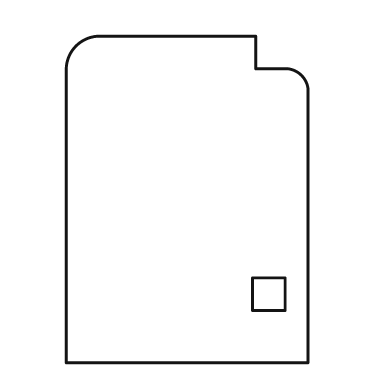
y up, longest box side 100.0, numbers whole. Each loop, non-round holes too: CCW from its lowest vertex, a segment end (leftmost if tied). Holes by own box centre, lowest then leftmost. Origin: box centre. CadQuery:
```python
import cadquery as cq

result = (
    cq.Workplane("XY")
    .moveTo(-37.0, -50.0)
    .lineTo(37.0, -50.0)
    .lineTo(37.0, 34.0)
    .threePointArc((35.0, 38.0), (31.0, 40.0))
    .lineTo(21.0, 40.0)
    .lineTo(21.0, 50.0)
    .lineTo(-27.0, 50.0)
    .threePointArc((-34.0, 47.0), (-37.0, 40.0))
    .close()
    .moveTo(20.0, -34.0)
    .lineTo(30.0, -34.0)
    .lineTo(30.0, -24.0)
    .lineTo(20.0, -24.0)
    .close()
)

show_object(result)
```